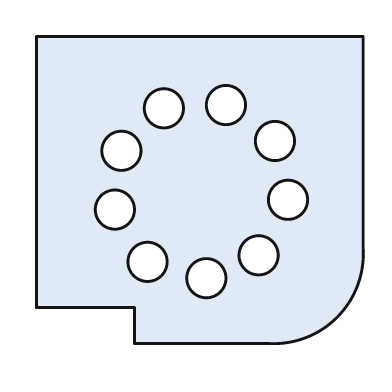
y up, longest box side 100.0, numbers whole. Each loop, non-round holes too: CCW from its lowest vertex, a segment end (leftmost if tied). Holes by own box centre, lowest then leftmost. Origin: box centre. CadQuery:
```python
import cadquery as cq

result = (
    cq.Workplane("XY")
    .moveTo(-20.0, -47.0)
    .lineTo(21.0, -47.0)
    .threePointArc((42.0, -39.0), (50.0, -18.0))
    .lineTo(50.0, 47.0)
    .lineTo(-50.0, 47.0)
    .lineTo(-50.0, -36.0)
    .lineTo(-20.0, -36.0)
    .close()
    .moveTo(2.0, -27.0)
    .circle(6.0)
    .moveTo(-16.0, -22.0)
    .circle(6.0)
    .moveTo(18.0, -20.0)
    .circle(6.0)
    .moveTo(-26.0, -6.0)
    .circle(6.0)
    .moveTo(27.0, -3.0)
    .circle(6.0)
    .moveTo(-24.0, 12.0)
    .circle(6.0)
    .moveTo(23.0, 15.0)
    .circle(6.0)
    .moveTo(-11.0, 25.0)
    .circle(6.0)
    .moveTo(8.0, 26.0)
    .circle(6.0)
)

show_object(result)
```